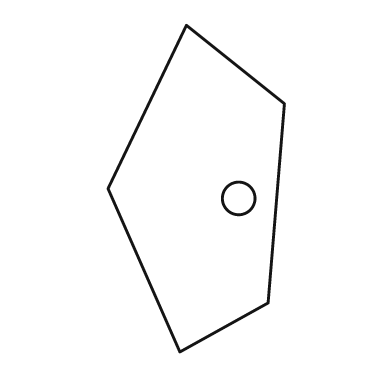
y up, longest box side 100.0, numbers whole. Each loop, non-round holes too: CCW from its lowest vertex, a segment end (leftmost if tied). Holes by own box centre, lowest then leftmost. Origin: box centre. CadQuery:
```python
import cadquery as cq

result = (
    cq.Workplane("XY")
    .moveTo(-5.0, -50.0)
    .lineTo(22.0, -35.0)
    .lineTo(27.0, 26.0)
    .lineTo(-3.0, 50.0)
    .lineTo(-27.0, 0.0)
    .close()
    .moveTo(13.0, -3.0)
    .circle(5.0)
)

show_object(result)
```